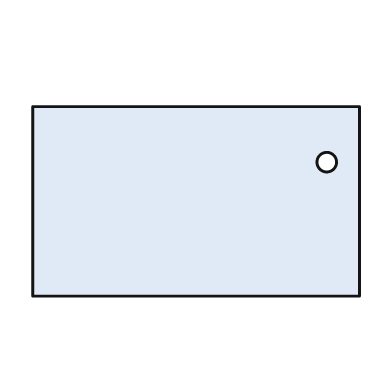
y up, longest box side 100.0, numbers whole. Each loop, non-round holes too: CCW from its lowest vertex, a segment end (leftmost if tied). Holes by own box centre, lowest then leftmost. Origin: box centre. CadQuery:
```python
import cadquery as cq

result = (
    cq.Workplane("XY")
    .moveTo(-50.0, -29.0)
    .lineTo(50.0, -29.0)
    .lineTo(50.0, 29.0)
    .lineTo(-50.0, 29.0)
    .close()
    .moveTo(40.0, 12.0)
    .circle(3.0)
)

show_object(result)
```